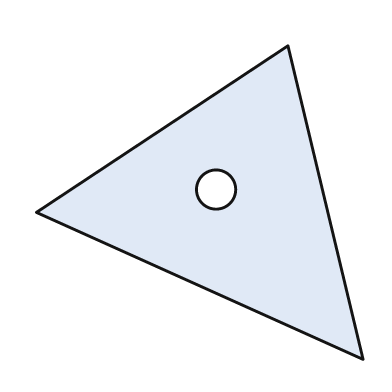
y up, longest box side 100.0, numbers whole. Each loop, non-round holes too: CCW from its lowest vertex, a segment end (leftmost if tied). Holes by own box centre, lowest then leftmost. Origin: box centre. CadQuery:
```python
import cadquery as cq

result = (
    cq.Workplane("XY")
    .moveTo(50.0, -48.0)
    .lineTo(27.0, 48.0)
    .lineTo(-50.0, -3.0)
    .close()
    .moveTo(5.0, 4.0)
    .circle(6.0)
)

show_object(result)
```